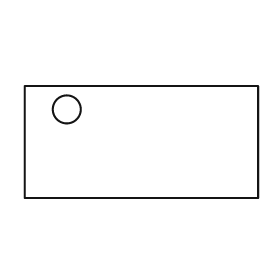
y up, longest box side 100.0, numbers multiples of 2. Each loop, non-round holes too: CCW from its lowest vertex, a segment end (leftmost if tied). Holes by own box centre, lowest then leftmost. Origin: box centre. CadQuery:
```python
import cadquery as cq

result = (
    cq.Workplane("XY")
    .moveTo(-50.0, -24.0)
    .lineTo(50.0, -24.0)
    .lineTo(50.0, 24.0)
    .lineTo(-50.0, 24.0)
    .close()
    .moveTo(-32.0, 14.0)
    .circle(6.0)
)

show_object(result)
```